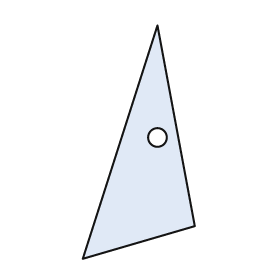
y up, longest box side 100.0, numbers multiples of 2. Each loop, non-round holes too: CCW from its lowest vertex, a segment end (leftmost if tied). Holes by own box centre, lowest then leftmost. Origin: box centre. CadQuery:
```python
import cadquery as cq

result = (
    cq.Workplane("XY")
    .moveTo(-24.0, -50.0)
    .lineTo(24.0, -36.0)
    .lineTo(8.0, 50.0)
    .close()
    .moveTo(8.0, 2.0)
    .circle(4.0)
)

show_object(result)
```